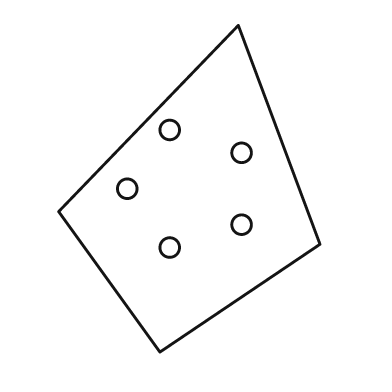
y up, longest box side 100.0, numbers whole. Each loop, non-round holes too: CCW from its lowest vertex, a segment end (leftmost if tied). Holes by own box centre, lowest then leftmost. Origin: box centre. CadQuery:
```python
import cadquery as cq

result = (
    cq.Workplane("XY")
    .moveTo(-9.0, -50.0)
    .lineTo(40.0, -17.0)
    .lineTo(15.0, 50.0)
    .lineTo(-40.0, -7.0)
    .close()
    .moveTo(-6.0, -18.0)
    .circle(3.0)
    .moveTo(16.0, -11.0)
    .circle(3.0)
    .moveTo(-19.0, 0.0)
    .circle(3.0)
    .moveTo(16.0, 11.0)
    .circle(3.0)
    .moveTo(-6.0, 18.0)
    .circle(3.0)
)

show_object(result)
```